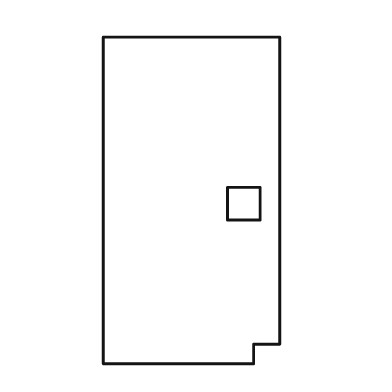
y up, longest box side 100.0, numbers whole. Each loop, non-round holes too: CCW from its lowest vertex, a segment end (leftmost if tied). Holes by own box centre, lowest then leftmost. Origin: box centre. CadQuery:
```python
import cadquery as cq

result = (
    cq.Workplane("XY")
    .moveTo(-27.0, -50.0)
    .lineTo(19.0, -50.0)
    .lineTo(19.0, -44.0)
    .lineTo(27.0, -44.0)
    .lineTo(27.0, 50.0)
    .lineTo(-27.0, 50.0)
    .close()
    .moveTo(11.0, -6.0)
    .lineTo(21.0, -6.0)
    .lineTo(21.0, 4.0)
    .lineTo(11.0, 4.0)
    .close()
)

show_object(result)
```